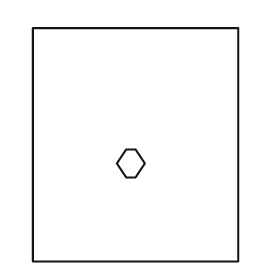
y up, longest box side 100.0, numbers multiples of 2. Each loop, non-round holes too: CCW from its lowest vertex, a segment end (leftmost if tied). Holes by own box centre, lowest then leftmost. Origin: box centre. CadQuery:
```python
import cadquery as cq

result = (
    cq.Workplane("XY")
    .moveTo(-44.0, -50.0)
    .lineTo(44.0, -50.0)
    .lineTo(44.0, 50.0)
    .lineTo(-44.0, 50.0)
    .close()
    .moveTo(-4.0, -14.0)
    .lineTo(0.0, -14.0)
    .lineTo(4.0, -8.0)
    .lineTo(0.0, -2.0)
    .lineTo(-4.0, -2.0)
    .lineTo(-8.0, -8.0)
    .close()
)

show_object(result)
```